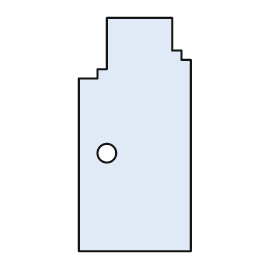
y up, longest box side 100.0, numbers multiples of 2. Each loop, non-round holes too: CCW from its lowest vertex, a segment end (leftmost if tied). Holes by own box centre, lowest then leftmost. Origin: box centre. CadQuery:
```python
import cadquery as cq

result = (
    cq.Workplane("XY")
    .moveTo(-24.0, -50.0)
    .lineTo(24.0, -50.0)
    .lineTo(24.0, 32.0)
    .lineTo(20.0, 32.0)
    .lineTo(20.0, 36.0)
    .lineTo(16.0, 36.0)
    .lineTo(16.0, 50.0)
    .lineTo(-12.0, 50.0)
    .lineTo(-12.0, 28.0)
    .lineTo(-16.0, 28.0)
    .lineTo(-16.0, 24.0)
    .lineTo(-24.0, 24.0)
    .close()
    .moveTo(-12.0, -8.0)
    .circle(4.0)
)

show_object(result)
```